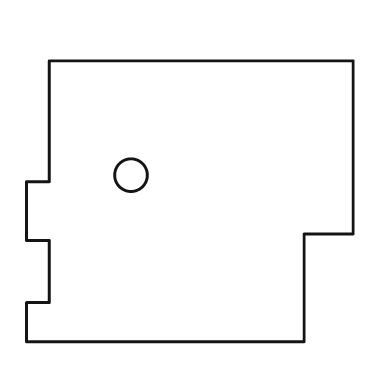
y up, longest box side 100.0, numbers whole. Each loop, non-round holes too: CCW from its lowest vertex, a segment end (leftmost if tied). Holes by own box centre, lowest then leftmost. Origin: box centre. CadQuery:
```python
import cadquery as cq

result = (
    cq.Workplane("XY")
    .moveTo(-50.0, -43.0)
    .lineTo(35.0, -43.0)
    .lineTo(35.0, -10.0)
    .lineTo(50.0, -10.0)
    .lineTo(50.0, 43.0)
    .lineTo(-43.0, 43.0)
    .lineTo(-43.0, 6.0)
    .lineTo(-50.0, 6.0)
    .lineTo(-50.0, -12.0)
    .lineTo(-43.0, -12.0)
    .lineTo(-43.0, -31.0)
    .lineTo(-50.0, -31.0)
    .close()
    .moveTo(-18.0, 8.0)
    .circle(5.0)
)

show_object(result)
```